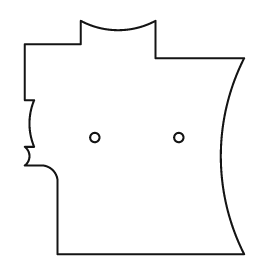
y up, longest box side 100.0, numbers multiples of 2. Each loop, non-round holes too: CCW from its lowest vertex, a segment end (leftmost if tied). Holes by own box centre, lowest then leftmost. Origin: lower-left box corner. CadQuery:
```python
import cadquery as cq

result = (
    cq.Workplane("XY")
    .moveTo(14.0, 0.0)
    .lineTo(94.0, 0.0)
    .threePointArc((84.0, 42.0), (94.0, 84.0))
    .lineTo(56.0, 84.0)
    .lineTo(56.0, 100.0)
    .threePointArc((40.0, 96.0), (24.0, 100.0))
    .lineTo(24.0, 90.0)
    .lineTo(0.0, 90.0)
    .lineTo(0.0, 66.0)
    .lineTo(4.0, 66.0)
    .threePointArc((2.0, 56.0), (4.0, 46.0))
    .lineTo(0.0, 46.0)
    .threePointArc((2.0, 42.0), (0.0, 38.0))
    .lineTo(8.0, 38.0)
    .threePointArc((12.0, 36.0), (14.0, 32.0))
    .close()
    .moveTo(30.0, 50.0)
    .circle(2.0)
    .moveTo(66.0, 50.0)
    .circle(2.0)
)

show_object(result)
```